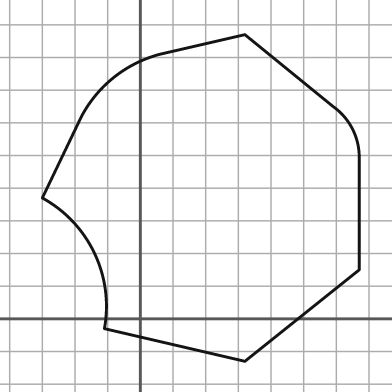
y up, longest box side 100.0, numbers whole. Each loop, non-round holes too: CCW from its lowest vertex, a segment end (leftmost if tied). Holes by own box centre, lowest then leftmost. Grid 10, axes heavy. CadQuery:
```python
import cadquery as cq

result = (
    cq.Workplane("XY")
    .moveTo(32.0, -13.0)
    .lineTo(67.0, 15.0)
    .lineTo(67.0, 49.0)
    .threePointArc((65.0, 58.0), (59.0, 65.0))
    .lineTo(32.0, 87.0)
    .lineTo(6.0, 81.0)
    .threePointArc((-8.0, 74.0), (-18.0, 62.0))
    .lineTo(-30.0, 37.0)
    .threePointArc((-14.0, 20.0), (-11.0, -3.0))
    .close()
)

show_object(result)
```